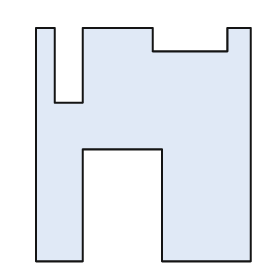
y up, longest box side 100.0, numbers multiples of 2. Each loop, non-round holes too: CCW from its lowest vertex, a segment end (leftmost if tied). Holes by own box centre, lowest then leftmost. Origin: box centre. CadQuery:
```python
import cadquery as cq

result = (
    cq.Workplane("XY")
    .moveTo(-46.0, -50.0)
    .lineTo(-26.0, -50.0)
    .lineTo(-26.0, -2.0)
    .lineTo(8.0, -2.0)
    .lineTo(8.0, -50.0)
    .lineTo(46.0, -50.0)
    .lineTo(46.0, 50.0)
    .lineTo(36.0, 50.0)
    .lineTo(36.0, 40.0)
    .lineTo(4.0, 40.0)
    .lineTo(4.0, 50.0)
    .lineTo(-26.0, 50.0)
    .lineTo(-26.0, 18.0)
    .lineTo(-38.0, 18.0)
    .lineTo(-38.0, 50.0)
    .lineTo(-46.0, 50.0)
    .close()
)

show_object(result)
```